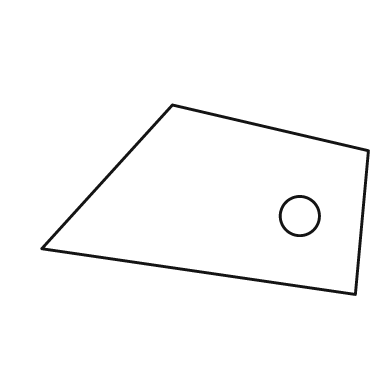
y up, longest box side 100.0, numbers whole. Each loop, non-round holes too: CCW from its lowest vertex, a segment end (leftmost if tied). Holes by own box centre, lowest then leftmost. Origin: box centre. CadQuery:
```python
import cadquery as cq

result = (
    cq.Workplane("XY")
    .moveTo(46.0, -29.0)
    .lineTo(50.0, 15.0)
    .lineTo(-10.0, 29.0)
    .lineTo(-50.0, -15.0)
    .close()
    .moveTo(29.0, -5.0)
    .circle(6.0)
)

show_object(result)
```